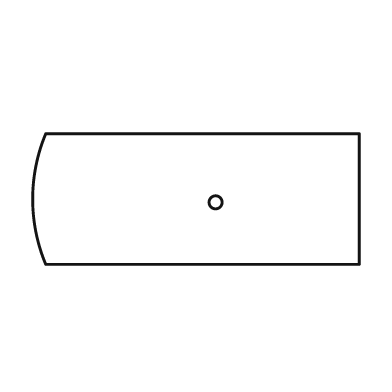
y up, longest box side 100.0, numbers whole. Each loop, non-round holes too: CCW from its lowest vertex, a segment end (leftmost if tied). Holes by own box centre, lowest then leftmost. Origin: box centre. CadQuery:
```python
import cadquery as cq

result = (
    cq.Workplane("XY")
    .moveTo(-46.0, -20.0)
    .lineTo(50.0, -20.0)
    .lineTo(50.0, 20.0)
    .lineTo(-46.0, 20.0)
    .threePointArc((-50.0, 0.0), (-46.0, -20.0))
    .close()
    .moveTo(6.0, -1.0)
    .circle(2.0)
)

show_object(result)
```